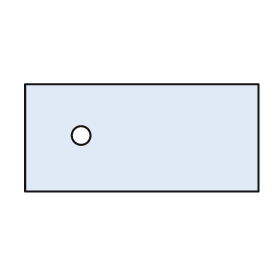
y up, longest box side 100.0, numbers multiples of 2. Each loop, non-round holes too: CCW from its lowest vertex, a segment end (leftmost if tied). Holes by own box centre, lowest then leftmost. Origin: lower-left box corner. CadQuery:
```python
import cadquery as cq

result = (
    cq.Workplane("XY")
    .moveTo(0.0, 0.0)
    .lineTo(100.0, 0.0)
    .lineTo(100.0, 46.0)
    .lineTo(0.0, 46.0)
    .close()
    .moveTo(24.0, 24.0)
    .circle(4.0)
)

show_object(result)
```